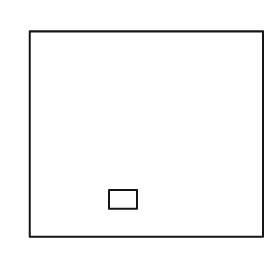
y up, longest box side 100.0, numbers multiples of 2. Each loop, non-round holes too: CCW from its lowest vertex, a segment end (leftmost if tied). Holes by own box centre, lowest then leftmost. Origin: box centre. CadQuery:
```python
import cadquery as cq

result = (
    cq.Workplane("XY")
    .moveTo(-50.0, -44.0)
    .lineTo(50.0, -44.0)
    .lineTo(50.0, 44.0)
    .lineTo(-50.0, 44.0)
    .close()
    .moveTo(-16.0, -32.0)
    .lineTo(-4.0, -32.0)
    .lineTo(-4.0, -24.0)
    .lineTo(-16.0, -24.0)
    .close()
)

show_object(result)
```